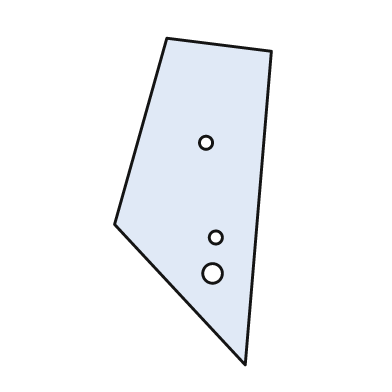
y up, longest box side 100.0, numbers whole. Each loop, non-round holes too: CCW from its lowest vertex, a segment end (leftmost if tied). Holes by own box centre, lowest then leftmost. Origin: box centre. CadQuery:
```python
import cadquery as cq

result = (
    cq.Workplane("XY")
    .moveTo(16.0, -50.0)
    .lineTo(24.0, 46.0)
    .lineTo(-8.0, 50.0)
    .lineTo(-24.0, -7.0)
    .close()
    .moveTo(6.0, -22.0)
    .circle(3.0)
    .moveTo(7.0, -11.0)
    .circle(2.0)
    .moveTo(4.0, 18.0)
    .circle(2.0)
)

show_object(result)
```